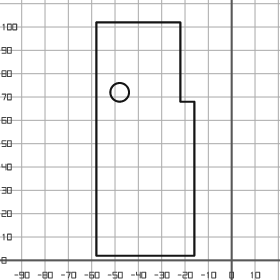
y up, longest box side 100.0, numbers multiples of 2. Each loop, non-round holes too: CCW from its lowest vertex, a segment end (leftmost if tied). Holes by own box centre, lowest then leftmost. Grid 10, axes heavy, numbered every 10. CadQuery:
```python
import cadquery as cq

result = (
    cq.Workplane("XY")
    .moveTo(-58.0, 2.0)
    .lineTo(-16.0, 2.0)
    .lineTo(-16.0, 68.0)
    .lineTo(-22.0, 68.0)
    .lineTo(-22.0, 102.0)
    .lineTo(-58.0, 102.0)
    .close()
    .moveTo(-48.0, 72.0)
    .circle(4.0)
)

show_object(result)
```